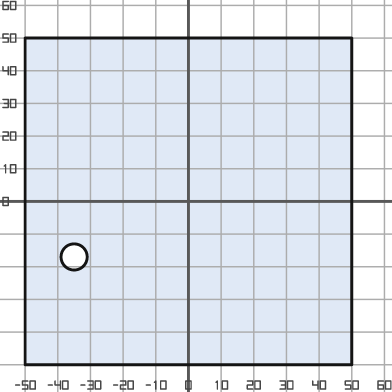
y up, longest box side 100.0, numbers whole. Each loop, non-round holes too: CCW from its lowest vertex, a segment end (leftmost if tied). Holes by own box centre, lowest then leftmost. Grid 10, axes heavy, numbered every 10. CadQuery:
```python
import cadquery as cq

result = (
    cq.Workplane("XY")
    .moveTo(-50.0, -50.0)
    .lineTo(50.0, -50.0)
    .lineTo(50.0, 50.0)
    .lineTo(-50.0, 50.0)
    .close()
    .moveTo(-35.0, -17.0)
    .circle(4.0)
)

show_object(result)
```